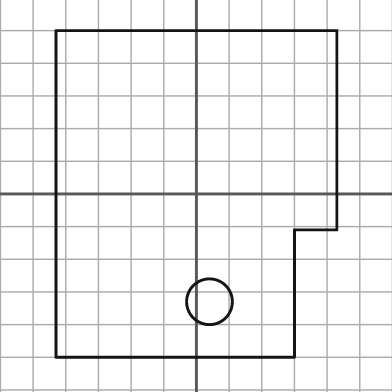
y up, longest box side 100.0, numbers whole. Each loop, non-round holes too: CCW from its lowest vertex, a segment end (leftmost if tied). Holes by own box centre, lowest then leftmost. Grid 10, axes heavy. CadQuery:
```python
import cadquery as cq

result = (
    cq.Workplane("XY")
    .moveTo(-43.0, -50.0)
    .lineTo(30.0, -50.0)
    .lineTo(30.0, -11.0)
    .lineTo(43.0, -11.0)
    .lineTo(43.0, 50.0)
    .lineTo(-43.0, 50.0)
    .close()
    .moveTo(4.0, -33.0)
    .circle(7.0)
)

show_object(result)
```